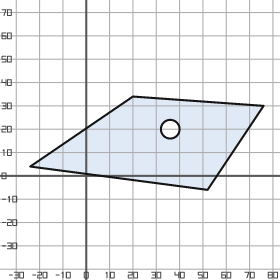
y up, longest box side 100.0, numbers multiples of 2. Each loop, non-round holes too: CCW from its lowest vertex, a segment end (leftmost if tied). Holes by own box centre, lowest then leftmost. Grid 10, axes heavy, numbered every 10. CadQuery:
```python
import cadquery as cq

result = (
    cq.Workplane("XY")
    .moveTo(52.0, -6.0)
    .lineTo(76.0, 30.0)
    .lineTo(20.0, 34.0)
    .lineTo(-24.0, 4.0)
    .close()
    .moveTo(36.0, 20.0)
    .circle(4.0)
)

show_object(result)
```